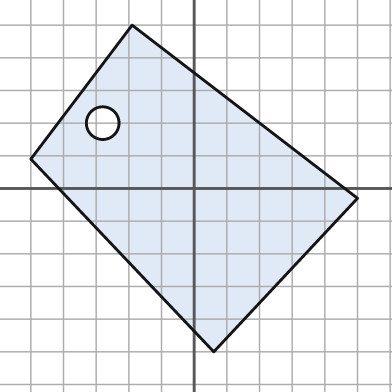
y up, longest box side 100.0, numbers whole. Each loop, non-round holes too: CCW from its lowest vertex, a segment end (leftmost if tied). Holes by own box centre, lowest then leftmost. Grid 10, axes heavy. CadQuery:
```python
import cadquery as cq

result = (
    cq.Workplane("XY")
    .moveTo(6.0, -50.0)
    .lineTo(50.0, -3.0)
    .lineTo(-19.0, 50.0)
    .lineTo(-50.0, 9.0)
    .close()
    .moveTo(-28.0, 20.0)
    .circle(5.0)
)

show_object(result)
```